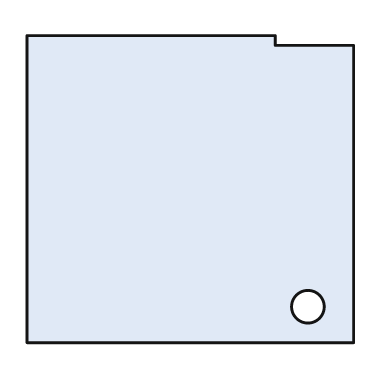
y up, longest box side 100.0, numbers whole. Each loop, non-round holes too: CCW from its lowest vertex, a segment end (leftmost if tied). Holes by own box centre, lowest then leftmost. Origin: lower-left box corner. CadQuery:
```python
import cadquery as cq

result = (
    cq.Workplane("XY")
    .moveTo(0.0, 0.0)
    .lineTo(100.0, 0.0)
    .lineTo(100.0, 91.0)
    .lineTo(76.0, 91.0)
    .lineTo(76.0, 94.0)
    .lineTo(0.0, 94.0)
    .close()
    .moveTo(86.0, 11.0)
    .circle(5.0)
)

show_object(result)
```